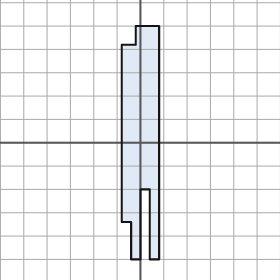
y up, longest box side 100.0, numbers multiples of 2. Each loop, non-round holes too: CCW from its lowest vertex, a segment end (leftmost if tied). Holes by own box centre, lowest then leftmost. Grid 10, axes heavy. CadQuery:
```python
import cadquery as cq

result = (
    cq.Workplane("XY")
    .moveTo(-4.0, -50.0)
    .lineTo(0.0, -50.0)
    .lineTo(0.0, -20.0)
    .lineTo(4.0, -20.0)
    .lineTo(4.0, -50.0)
    .lineTo(8.0, -50.0)
    .lineTo(8.0, 50.0)
    .lineTo(-2.0, 50.0)
    .lineTo(-2.0, 42.0)
    .lineTo(-8.0, 42.0)
    .lineTo(-8.0, -34.0)
    .lineTo(-4.0, -34.0)
    .close()
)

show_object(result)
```